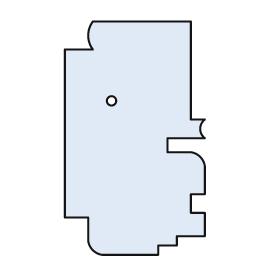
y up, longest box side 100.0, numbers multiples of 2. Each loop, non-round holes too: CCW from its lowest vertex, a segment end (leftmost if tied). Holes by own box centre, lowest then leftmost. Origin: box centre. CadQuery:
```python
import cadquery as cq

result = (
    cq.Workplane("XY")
    .moveTo(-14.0, -50.0)
    .lineTo(10.0, -50.0)
    .lineTo(10.0, -46.0)
    .lineTo(18.0, -46.0)
    .lineTo(18.0, -42.0)
    .lineTo(30.0, -42.0)
    .lineTo(30.0, -32.0)
    .lineTo(24.0, -32.0)
    .lineTo(24.0, -24.0)
    .lineTo(30.0, -24.0)
    .lineTo(30.0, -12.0)
    .threePointArc((28.0, -8.0), (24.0, -6.0))
    .lineTo(14.0, -6.0)
    .lineTo(14.0, 0.0)
    .lineTo(30.0, 0.0)
    .threePointArc((28.0, 4.0), (30.0, 8.0))
    .lineTo(24.0, 8.0)
    .lineTo(24.0, 50.0)
    .lineTo(-18.0, 50.0)
    .threePointArc((-20.0, 44.0), (-18.0, 38.0))
    .lineTo(-30.0, 38.0)
    .lineTo(-30.0, -34.0)
    .lineTo(-20.0, -34.0)
    .lineTo(-20.0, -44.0)
    .threePointArc((-18.0, -48.0), (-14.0, -50.0))
    .close()
    .moveTo(-10.0, 16.0)
    .circle(2.0)
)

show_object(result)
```